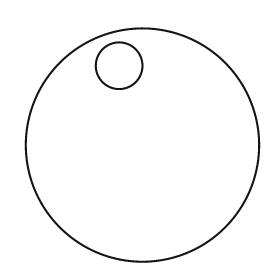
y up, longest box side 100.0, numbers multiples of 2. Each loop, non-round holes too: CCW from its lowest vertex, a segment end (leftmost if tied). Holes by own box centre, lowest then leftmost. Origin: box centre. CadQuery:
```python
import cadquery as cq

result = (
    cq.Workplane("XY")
    .moveTo(0.0, 0.0)
    .circle(50.0)
    .moveTo(-10.0, 34.0)
    .circle(10.0)
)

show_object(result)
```